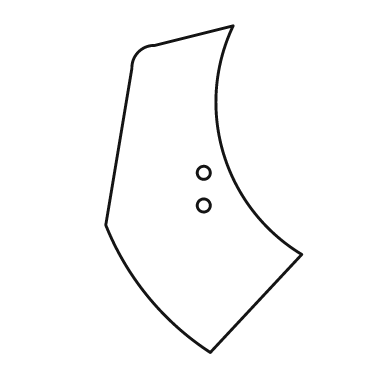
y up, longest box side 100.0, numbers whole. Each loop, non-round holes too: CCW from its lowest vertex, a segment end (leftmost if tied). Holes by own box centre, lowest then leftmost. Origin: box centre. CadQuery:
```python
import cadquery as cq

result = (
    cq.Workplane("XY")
    .moveTo(2.0, -50.0)
    .lineTo(30.0, -20.0)
    .threePointArc((6.0, 11.0), (9.0, 50.0))
    .lineTo(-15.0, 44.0)
    .threePointArc((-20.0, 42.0), (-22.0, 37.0))
    .lineTo(-30.0, -11.0)
    .threePointArc((-17.0, -33.0), (2.0, -50.0))
    .close()
    .moveTo(0.0, -5.0)
    .circle(2.0)
    .moveTo(0.0, 5.0)
    .circle(2.0)
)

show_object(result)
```